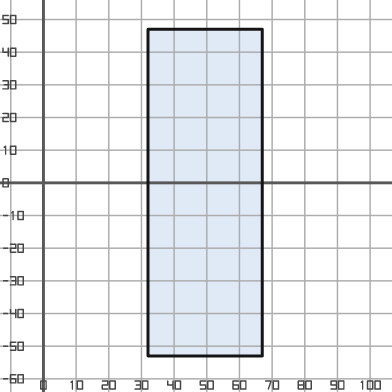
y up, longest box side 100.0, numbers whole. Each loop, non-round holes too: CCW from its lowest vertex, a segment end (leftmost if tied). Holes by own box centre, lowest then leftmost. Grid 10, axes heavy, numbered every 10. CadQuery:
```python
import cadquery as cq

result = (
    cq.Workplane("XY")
    .moveTo(32.0, -53.0)
    .lineTo(67.0, -53.0)
    .lineTo(67.0, 47.0)
    .lineTo(32.0, 47.0)
    .close()
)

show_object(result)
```